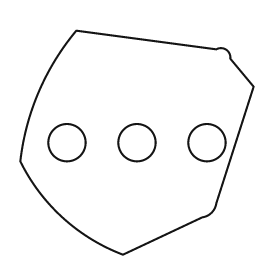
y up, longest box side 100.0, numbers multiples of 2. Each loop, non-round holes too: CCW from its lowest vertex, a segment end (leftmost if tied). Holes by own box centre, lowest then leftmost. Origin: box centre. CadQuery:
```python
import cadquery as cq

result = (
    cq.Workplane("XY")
    .moveTo(-6.0, -48.0)
    .lineTo(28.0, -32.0)
    .threePointArc((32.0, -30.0), (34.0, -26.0))
    .lineTo(50.0, 24.0)
    .lineTo(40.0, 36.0)
    .threePointArc((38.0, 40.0), (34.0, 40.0))
    .lineTo(-26.0, 48.0)
    .threePointArc((-42.0, 22.0), (-50.0, -8.0))
    .threePointArc((-32.0, -32.0), (-6.0, -48.0))
    .close()
    .moveTo(-30.0, 0.0)
    .circle(8.0)
    .moveTo(0.0, 0.0)
    .circle(8.0)
    .moveTo(30.0, 0.0)
    .circle(8.0)
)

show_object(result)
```